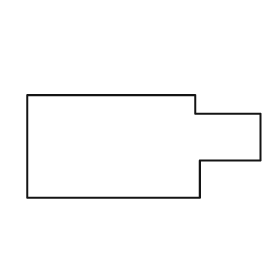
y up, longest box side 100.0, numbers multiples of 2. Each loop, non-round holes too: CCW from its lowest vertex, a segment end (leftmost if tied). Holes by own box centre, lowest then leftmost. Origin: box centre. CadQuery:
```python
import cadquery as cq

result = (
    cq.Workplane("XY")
    .moveTo(-50.0, -22.0)
    .lineTo(24.0, -22.0)
    .lineTo(24.0, -6.0)
    .lineTo(50.0, -6.0)
    .lineTo(50.0, 14.0)
    .lineTo(22.0, 14.0)
    .lineTo(22.0, 22.0)
    .lineTo(-50.0, 22.0)
    .close()
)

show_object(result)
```